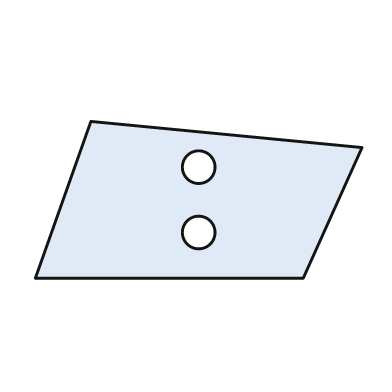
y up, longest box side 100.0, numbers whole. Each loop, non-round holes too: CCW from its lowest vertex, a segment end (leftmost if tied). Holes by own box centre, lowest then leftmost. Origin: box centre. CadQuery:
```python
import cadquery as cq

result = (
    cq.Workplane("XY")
    .moveTo(-50.0, -24.0)
    .lineTo(32.0, -24.0)
    .lineTo(50.0, 16.0)
    .lineTo(-33.0, 24.0)
    .close()
    .moveTo(0.0, -10.0)
    .circle(5.0)
    .moveTo(0.0, 10.0)
    .circle(5.0)
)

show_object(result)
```